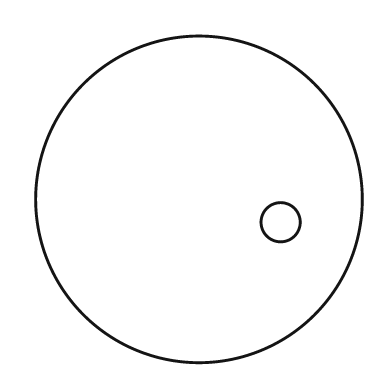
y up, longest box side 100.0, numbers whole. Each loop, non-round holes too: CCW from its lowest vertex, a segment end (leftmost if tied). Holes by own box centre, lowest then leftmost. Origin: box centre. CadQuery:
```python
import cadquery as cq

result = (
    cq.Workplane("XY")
    .moveTo(0.0, 0.0)
    .circle(50.0)
    .moveTo(25.0, -7.0)
    .circle(6.0)
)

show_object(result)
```